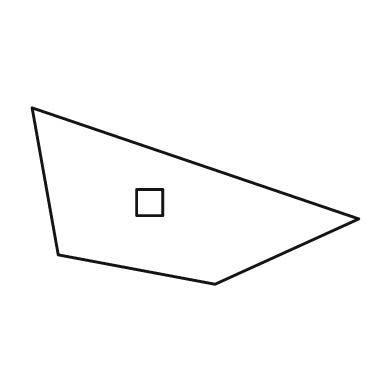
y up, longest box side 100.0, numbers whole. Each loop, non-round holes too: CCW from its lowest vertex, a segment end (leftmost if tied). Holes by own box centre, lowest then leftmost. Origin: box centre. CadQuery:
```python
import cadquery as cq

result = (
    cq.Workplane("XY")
    .moveTo(6.0, -27.0)
    .lineTo(50.0, -7.0)
    .lineTo(-50.0, 27.0)
    .lineTo(-42.0, -18.0)
    .close()
    .moveTo(-18.0, -6.0)
    .lineTo(-10.0, -6.0)
    .lineTo(-10.0, 2.0)
    .lineTo(-18.0, 2.0)
    .close()
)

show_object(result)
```